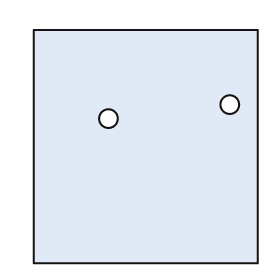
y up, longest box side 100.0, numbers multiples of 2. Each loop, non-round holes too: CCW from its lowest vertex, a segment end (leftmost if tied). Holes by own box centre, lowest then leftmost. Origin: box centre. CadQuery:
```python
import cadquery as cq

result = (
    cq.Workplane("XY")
    .moveTo(-48.0, -50.0)
    .lineTo(48.0, -50.0)
    .lineTo(48.0, 50.0)
    .lineTo(-48.0, 50.0)
    .close()
    .moveTo(-16.0, 12.0)
    .circle(4.0)
    .moveTo(36.0, 18.0)
    .circle(4.0)
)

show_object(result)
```